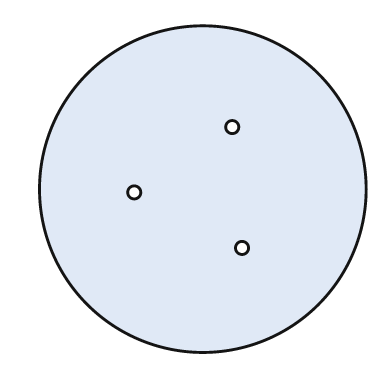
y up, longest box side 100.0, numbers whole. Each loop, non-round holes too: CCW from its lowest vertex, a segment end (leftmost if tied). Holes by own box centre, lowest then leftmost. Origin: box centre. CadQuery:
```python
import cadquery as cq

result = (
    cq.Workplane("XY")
    .moveTo(0.0, 0.0)
    .circle(50.0)
    .moveTo(12.0, -18.0)
    .circle(2.0)
    .moveTo(-21.0, -1.0)
    .circle(2.0)
    .moveTo(9.0, 19.0)
    .circle(2.0)
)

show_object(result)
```